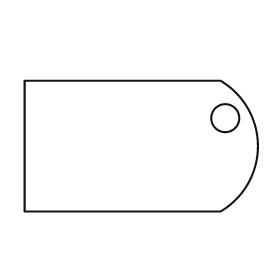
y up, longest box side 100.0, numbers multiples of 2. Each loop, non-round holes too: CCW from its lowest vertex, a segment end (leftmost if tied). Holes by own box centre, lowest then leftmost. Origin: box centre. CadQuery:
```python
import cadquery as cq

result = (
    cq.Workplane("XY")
    .moveTo(-50.0, -28.0)
    .lineTo(34.0, -28.0)
    .threePointArc((50.0, 0.0), (34.0, 28.0))
    .lineTo(-50.0, 28.0)
    .close()
    .moveTo(36.0, 12.0)
    .circle(6.0)
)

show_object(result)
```